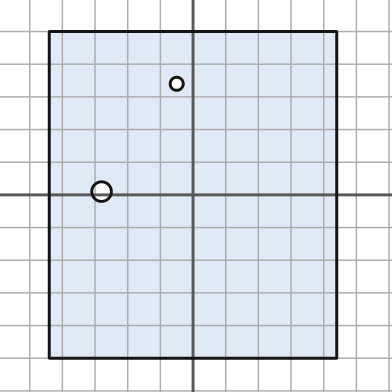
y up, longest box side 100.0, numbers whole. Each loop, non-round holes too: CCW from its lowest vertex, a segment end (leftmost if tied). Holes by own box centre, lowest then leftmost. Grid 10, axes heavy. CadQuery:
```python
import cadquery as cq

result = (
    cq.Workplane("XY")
    .moveTo(-44.0, -50.0)
    .lineTo(44.0, -50.0)
    .lineTo(44.0, 50.0)
    .lineTo(-44.0, 50.0)
    .close()
    .moveTo(-28.0, 1.0)
    .circle(3.0)
    .moveTo(-5.0, 34.0)
    .circle(2.0)
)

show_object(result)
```